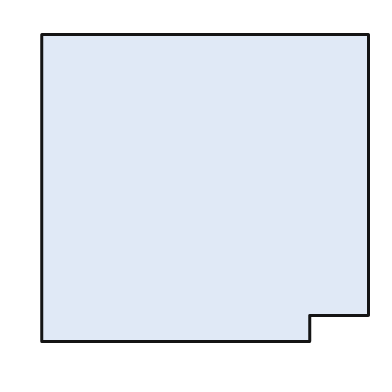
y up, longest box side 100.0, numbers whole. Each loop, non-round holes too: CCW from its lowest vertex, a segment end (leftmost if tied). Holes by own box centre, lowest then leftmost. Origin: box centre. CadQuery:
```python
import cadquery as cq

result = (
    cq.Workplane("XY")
    .moveTo(-50.0, -47.0)
    .lineTo(32.0, -47.0)
    .lineTo(32.0, -39.0)
    .lineTo(50.0, -39.0)
    .lineTo(50.0, 47.0)
    .lineTo(-50.0, 47.0)
    .close()
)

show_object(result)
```